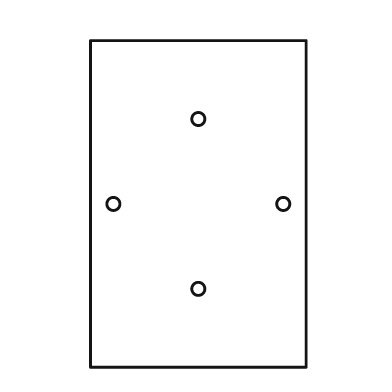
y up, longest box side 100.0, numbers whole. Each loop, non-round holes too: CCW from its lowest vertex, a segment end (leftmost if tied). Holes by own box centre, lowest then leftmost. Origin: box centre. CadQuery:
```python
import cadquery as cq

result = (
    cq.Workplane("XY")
    .moveTo(-33.0, -50.0)
    .lineTo(33.0, -50.0)
    .lineTo(33.0, 50.0)
    .lineTo(-33.0, 50.0)
    .close()
    .moveTo(0.0, -26.0)
    .circle(2.0)
    .moveTo(-26.0, 0.0)
    .circle(2.0)
    .moveTo(26.0, 0.0)
    .circle(2.0)
    .moveTo(0.0, 26.0)
    .circle(2.0)
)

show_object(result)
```